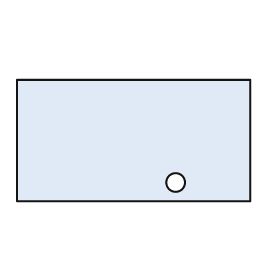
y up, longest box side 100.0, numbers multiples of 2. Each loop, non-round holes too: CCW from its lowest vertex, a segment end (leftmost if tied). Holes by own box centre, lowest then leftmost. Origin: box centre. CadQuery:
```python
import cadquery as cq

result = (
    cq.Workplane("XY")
    .moveTo(-50.0, -26.0)
    .lineTo(50.0, -26.0)
    .lineTo(50.0, 26.0)
    .lineTo(-50.0, 26.0)
    .close()
    .moveTo(18.0, -18.0)
    .circle(4.0)
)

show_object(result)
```